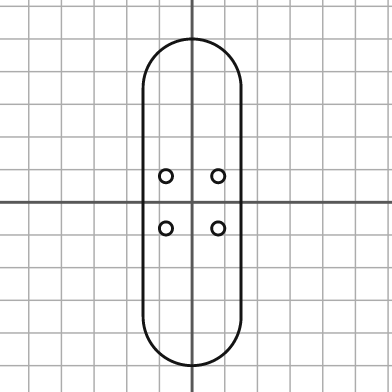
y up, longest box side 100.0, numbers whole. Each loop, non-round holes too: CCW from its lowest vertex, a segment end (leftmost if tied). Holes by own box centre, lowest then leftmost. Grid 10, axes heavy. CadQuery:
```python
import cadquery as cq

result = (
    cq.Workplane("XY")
    .moveTo(-15.0, -35.0)
    .threePointArc((0.0, -50.0), (15.0, -35.0))
    .lineTo(15.0, 35.0)
    .threePointArc((0.0, 50.0), (-15.0, 35.0))
    .close()
    .moveTo(-8.0, -8.0)
    .circle(2.0)
    .moveTo(8.0, -8.0)
    .circle(2.0)
    .moveTo(-8.0, 8.0)
    .circle(2.0)
    .moveTo(8.0, 8.0)
    .circle(2.0)
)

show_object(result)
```